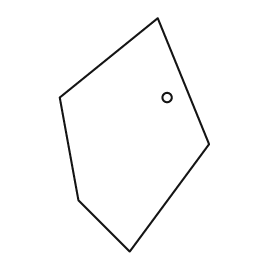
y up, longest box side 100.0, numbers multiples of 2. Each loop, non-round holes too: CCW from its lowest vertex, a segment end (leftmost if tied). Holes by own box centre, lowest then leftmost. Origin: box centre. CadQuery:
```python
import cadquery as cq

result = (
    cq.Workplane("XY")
    .moveTo(-2.0, -50.0)
    .lineTo(32.0, -4.0)
    .lineTo(10.0, 50.0)
    .lineTo(-32.0, 16.0)
    .lineTo(-24.0, -28.0)
    .close()
    .moveTo(14.0, 16.0)
    .circle(2.0)
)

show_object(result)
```